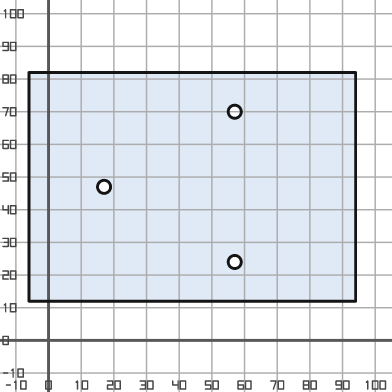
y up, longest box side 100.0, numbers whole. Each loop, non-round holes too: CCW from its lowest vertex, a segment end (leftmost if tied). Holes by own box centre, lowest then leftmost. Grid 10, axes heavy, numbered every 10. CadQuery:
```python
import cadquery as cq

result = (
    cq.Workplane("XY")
    .moveTo(-6.0, 12.0)
    .lineTo(94.0, 12.0)
    .lineTo(94.0, 82.0)
    .lineTo(-6.0, 82.0)
    .close()
    .moveTo(57.0, 24.0)
    .circle(2.0)
    .moveTo(17.0, 47.0)
    .circle(2.0)
    .moveTo(57.0, 70.0)
    .circle(2.0)
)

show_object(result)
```